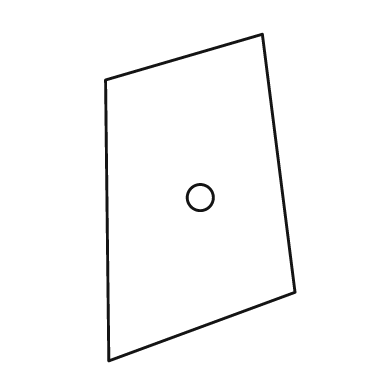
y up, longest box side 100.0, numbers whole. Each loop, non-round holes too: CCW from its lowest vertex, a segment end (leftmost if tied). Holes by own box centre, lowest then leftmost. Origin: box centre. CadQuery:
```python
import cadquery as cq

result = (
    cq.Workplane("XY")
    .moveTo(-28.0, -50.0)
    .lineTo(29.0, -29.0)
    .lineTo(19.0, 50.0)
    .lineTo(-29.0, 36.0)
    .close()
    .moveTo(0.0, 0.0)
    .circle(4.0)
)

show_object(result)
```